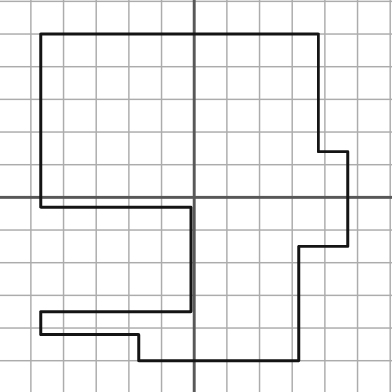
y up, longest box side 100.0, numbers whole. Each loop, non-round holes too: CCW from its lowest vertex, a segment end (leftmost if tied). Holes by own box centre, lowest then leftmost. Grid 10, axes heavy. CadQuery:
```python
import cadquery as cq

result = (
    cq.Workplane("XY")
    .moveTo(-17.0, -50.0)
    .lineTo(32.0, -50.0)
    .lineTo(32.0, -15.0)
    .lineTo(47.0, -15.0)
    .lineTo(47.0, 14.0)
    .lineTo(38.0, 14.0)
    .lineTo(38.0, 50.0)
    .lineTo(-47.0, 50.0)
    .lineTo(-47.0, -3.0)
    .lineTo(-1.0, -3.0)
    .lineTo(-1.0, -35.0)
    .lineTo(-47.0, -35.0)
    .lineTo(-47.0, -42.0)
    .lineTo(-17.0, -42.0)
    .close()
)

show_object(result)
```